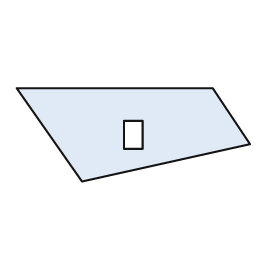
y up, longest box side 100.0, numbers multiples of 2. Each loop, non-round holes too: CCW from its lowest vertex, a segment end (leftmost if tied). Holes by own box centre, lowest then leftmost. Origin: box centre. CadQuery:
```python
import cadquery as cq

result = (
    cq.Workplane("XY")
    .moveTo(-22.0, -20.0)
    .lineTo(50.0, -4.0)
    .lineTo(34.0, 20.0)
    .lineTo(-50.0, 20.0)
    .close()
    .moveTo(-4.0, -6.0)
    .lineTo(4.0, -6.0)
    .lineTo(4.0, 6.0)
    .lineTo(-4.0, 6.0)
    .close()
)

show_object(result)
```